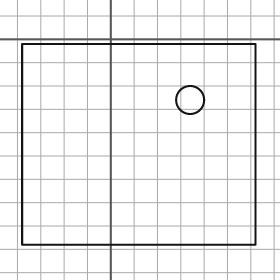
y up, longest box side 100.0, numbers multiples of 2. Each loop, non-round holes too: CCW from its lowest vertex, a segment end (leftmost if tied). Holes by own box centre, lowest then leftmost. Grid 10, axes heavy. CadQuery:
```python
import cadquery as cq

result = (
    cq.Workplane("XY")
    .moveTo(-38.0, -88.0)
    .lineTo(62.0, -88.0)
    .lineTo(62.0, -2.0)
    .lineTo(-38.0, -2.0)
    .close()
    .moveTo(34.0, -26.0)
    .circle(6.0)
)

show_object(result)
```